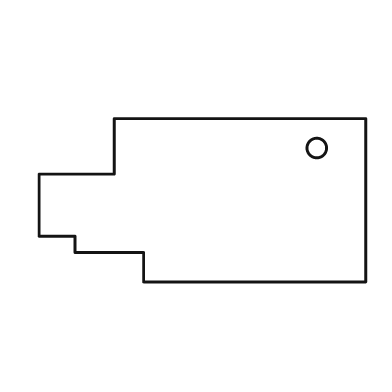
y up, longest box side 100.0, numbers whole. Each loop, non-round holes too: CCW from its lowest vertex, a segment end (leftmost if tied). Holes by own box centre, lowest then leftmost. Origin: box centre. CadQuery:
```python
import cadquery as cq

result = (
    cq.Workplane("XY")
    .moveTo(-18.0, -25.0)
    .lineTo(50.0, -25.0)
    .lineTo(50.0, 25.0)
    .lineTo(-27.0, 25.0)
    .lineTo(-27.0, 8.0)
    .lineTo(-50.0, 8.0)
    .lineTo(-50.0, -11.0)
    .lineTo(-39.0, -11.0)
    .lineTo(-39.0, -16.0)
    .lineTo(-18.0, -16.0)
    .close()
    .moveTo(35.0, 16.0)
    .circle(3.0)
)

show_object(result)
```